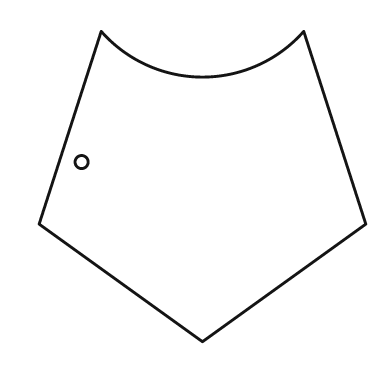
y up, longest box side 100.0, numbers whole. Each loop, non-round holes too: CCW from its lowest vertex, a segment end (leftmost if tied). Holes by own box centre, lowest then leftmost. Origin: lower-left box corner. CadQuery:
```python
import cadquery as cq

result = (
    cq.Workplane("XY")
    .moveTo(50.0, 0.0)
    .lineTo(100.0, 36.0)
    .lineTo(81.0, 95.0)
    .threePointArc((50.0, 81.0), (19.0, 95.0))
    .lineTo(0.0, 36.0)
    .close()
    .moveTo(13.0, 55.0)
    .circle(2.0)
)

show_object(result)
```